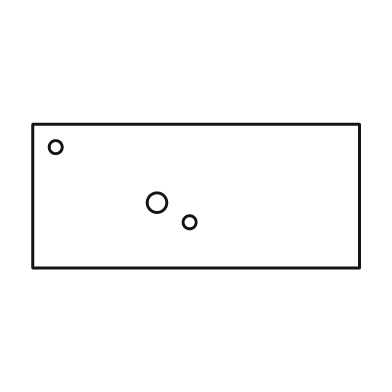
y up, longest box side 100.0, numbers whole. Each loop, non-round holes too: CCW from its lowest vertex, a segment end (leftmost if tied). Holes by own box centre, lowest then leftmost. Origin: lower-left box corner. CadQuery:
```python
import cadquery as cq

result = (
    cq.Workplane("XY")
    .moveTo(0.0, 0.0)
    .lineTo(100.0, 0.0)
    .lineTo(100.0, 44.0)
    .lineTo(0.0, 44.0)
    .close()
    .moveTo(48.0, 14.0)
    .circle(2.0)
    .moveTo(38.0, 20.0)
    .circle(3.0)
    .moveTo(7.0, 37.0)
    .circle(2.0)
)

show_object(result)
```